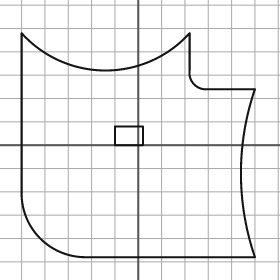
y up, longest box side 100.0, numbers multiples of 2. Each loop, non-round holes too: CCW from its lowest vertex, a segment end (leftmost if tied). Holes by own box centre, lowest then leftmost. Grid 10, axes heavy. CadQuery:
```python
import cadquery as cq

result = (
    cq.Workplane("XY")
    .moveTo(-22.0, -48.0)
    .lineTo(50.0, -48.0)
    .threePointArc((44.0, -12.0), (50.0, 24.0))
    .lineTo(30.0, 24.0)
    .threePointArc((24.0, 26.0), (22.0, 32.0))
    .lineTo(22.0, 48.0)
    .threePointArc((-14.0, 32.0), (-50.0, 48.0))
    .lineTo(-50.0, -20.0)
    .threePointArc((-42.0, -40.0), (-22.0, -48.0))
    .close()
    .moveTo(-10.0, 0.0)
    .lineTo(2.0, 0.0)
    .lineTo(2.0, 8.0)
    .lineTo(-10.0, 8.0)
    .close()
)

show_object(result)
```